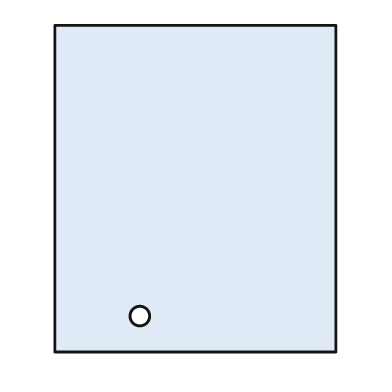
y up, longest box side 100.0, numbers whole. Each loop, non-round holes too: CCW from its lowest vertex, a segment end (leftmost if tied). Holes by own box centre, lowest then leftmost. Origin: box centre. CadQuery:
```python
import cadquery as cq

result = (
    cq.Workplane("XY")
    .moveTo(-43.0, -50.0)
    .lineTo(43.0, -50.0)
    .lineTo(43.0, 50.0)
    .lineTo(-43.0, 50.0)
    .close()
    .moveTo(-17.0, -39.0)
    .circle(3.0)
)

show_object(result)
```